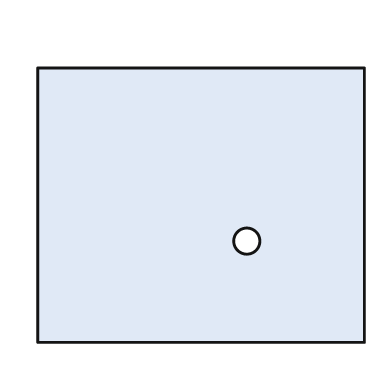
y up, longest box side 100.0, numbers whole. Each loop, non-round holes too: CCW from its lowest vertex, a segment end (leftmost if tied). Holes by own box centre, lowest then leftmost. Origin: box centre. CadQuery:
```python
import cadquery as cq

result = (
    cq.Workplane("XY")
    .moveTo(-50.0, -42.0)
    .lineTo(50.0, -42.0)
    .lineTo(50.0, 42.0)
    .lineTo(-50.0, 42.0)
    .close()
    .moveTo(14.0, -11.0)
    .circle(4.0)
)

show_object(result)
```